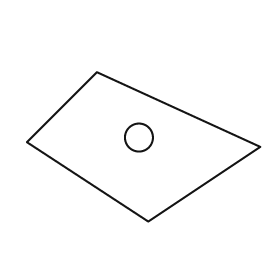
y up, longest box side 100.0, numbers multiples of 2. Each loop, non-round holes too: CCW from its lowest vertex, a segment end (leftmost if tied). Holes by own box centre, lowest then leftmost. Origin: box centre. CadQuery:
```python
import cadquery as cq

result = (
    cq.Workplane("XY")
    .moveTo(2.0, -32.0)
    .lineTo(50.0, 0.0)
    .lineTo(-20.0, 32.0)
    .lineTo(-50.0, 2.0)
    .close()
    .moveTo(-2.0, 4.0)
    .circle(6.0)
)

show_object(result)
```